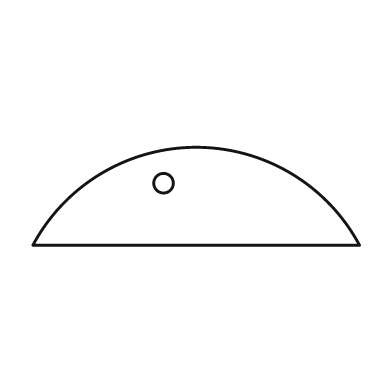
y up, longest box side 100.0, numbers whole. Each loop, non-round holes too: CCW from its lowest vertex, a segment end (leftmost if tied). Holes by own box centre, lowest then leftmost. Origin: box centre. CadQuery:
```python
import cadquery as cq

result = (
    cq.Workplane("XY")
    .moveTo(-50.0, -15.0)
    .lineTo(50.0, -15.0)
    .threePointArc((0.0, 15.0), (-50.0, -15.0))
    .close()
    .moveTo(-10.0, 4.0)
    .circle(3.0)
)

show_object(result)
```